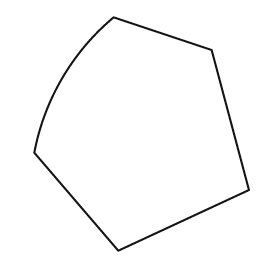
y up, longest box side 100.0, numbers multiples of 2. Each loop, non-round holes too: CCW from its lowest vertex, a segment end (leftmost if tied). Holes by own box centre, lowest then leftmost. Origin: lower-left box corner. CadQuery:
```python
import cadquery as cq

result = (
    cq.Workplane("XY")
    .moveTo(36.0, 0.0)
    .lineTo(92.0, 26.0)
    .lineTo(76.0, 86.0)
    .lineTo(34.0, 100.0)
    .threePointArc((12.0, 74.0), (0.0, 42.0))
    .close()
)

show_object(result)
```